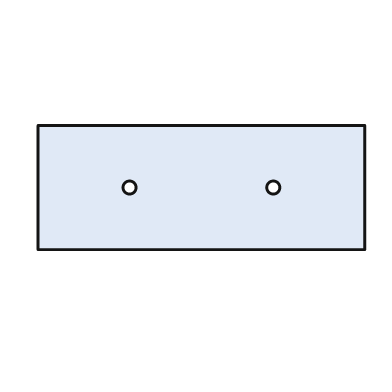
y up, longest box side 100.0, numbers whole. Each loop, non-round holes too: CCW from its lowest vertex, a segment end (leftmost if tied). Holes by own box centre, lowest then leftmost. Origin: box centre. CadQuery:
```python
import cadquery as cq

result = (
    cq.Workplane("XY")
    .moveTo(-50.0, -19.0)
    .lineTo(50.0, -19.0)
    .lineTo(50.0, 19.0)
    .lineTo(-50.0, 19.0)
    .close()
    .moveTo(-22.0, 0.0)
    .circle(2.0)
    .moveTo(22.0, 0.0)
    .circle(2.0)
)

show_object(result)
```